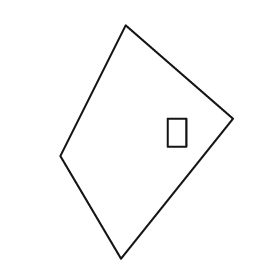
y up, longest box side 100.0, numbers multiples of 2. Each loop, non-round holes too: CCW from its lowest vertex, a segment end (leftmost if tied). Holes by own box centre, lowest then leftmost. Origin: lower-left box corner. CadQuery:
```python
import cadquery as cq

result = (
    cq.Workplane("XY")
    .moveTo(26.0, 0.0)
    .lineTo(74.0, 60.0)
    .lineTo(28.0, 100.0)
    .lineTo(0.0, 44.0)
    .close()
    .moveTo(46.0, 48.0)
    .lineTo(54.0, 48.0)
    .lineTo(54.0, 60.0)
    .lineTo(46.0, 60.0)
    .close()
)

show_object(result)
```